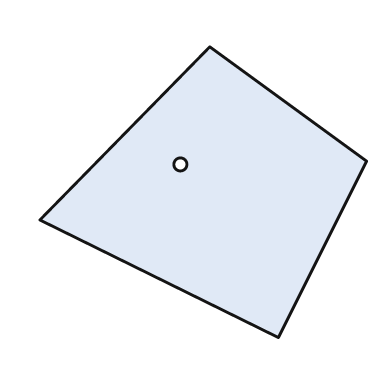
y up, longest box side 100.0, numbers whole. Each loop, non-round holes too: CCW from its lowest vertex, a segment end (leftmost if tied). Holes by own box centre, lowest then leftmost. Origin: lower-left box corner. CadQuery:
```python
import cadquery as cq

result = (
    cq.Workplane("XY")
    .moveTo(73.0, 0.0)
    .lineTo(100.0, 54.0)
    .lineTo(52.0, 89.0)
    .lineTo(0.0, 36.0)
    .close()
    .moveTo(43.0, 53.0)
    .circle(2.0)
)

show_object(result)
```